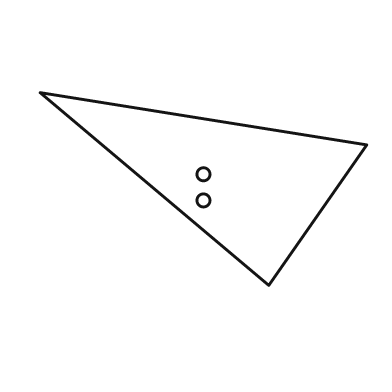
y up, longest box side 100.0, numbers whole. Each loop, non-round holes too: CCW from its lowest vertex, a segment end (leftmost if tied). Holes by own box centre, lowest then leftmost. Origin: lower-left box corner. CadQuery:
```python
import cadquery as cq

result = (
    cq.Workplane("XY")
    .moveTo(70.0, 0.0)
    .lineTo(100.0, 43.0)
    .lineTo(0.0, 59.0)
    .close()
    .moveTo(50.0, 26.0)
    .circle(2.0)
    .moveTo(50.0, 34.0)
    .circle(2.0)
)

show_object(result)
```